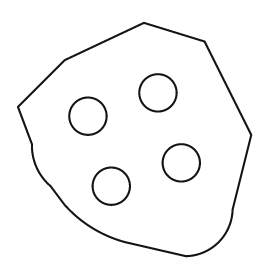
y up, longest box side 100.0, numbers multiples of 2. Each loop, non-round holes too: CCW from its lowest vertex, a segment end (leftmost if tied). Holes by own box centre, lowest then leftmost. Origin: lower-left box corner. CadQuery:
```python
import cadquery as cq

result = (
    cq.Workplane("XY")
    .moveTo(72.0, 0.0)
    .threePointArc((86.0, 6.0), (92.0, 20.0))
    .lineTo(100.0, 52.0)
    .lineTo(80.0, 92.0)
    .lineTo(54.0, 100.0)
    .lineTo(20.0, 84.0)
    .lineTo(0.0, 64.0)
    .lineTo(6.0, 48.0)
    .threePointArc((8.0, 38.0), (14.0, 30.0))
    .lineTo(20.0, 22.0)
    .threePointArc((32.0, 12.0), (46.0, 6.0))
    .close()
    .moveTo(40.0, 30.0)
    .circle(8.0)
    .moveTo(70.0, 40.0)
    .circle(8.0)
    .moveTo(30.0, 60.0)
    .circle(8.0)
    .moveTo(60.0, 70.0)
    .circle(8.0)
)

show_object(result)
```